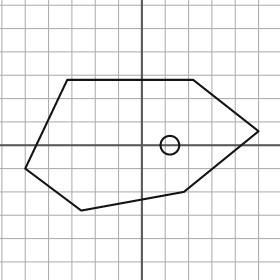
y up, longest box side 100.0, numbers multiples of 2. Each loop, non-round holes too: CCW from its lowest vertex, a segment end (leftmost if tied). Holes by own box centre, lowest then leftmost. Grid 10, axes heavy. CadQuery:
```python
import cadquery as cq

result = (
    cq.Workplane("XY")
    .moveTo(-26.0, -28.0)
    .lineTo(18.0, -20.0)
    .lineTo(50.0, 6.0)
    .lineTo(22.0, 28.0)
    .lineTo(-32.0, 28.0)
    .lineTo(-50.0, -10.0)
    .close()
    .moveTo(12.0, 0.0)
    .circle(4.0)
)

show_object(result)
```